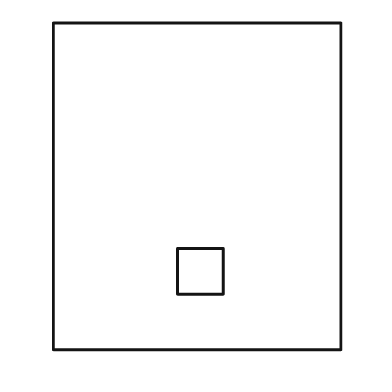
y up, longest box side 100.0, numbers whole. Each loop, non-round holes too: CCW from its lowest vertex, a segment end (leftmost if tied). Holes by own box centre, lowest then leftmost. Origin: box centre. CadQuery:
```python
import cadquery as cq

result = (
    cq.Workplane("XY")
    .moveTo(-44.0, -50.0)
    .lineTo(44.0, -50.0)
    .lineTo(44.0, 50.0)
    .lineTo(-44.0, 50.0)
    .close()
    .moveTo(-6.0, -33.0)
    .lineTo(8.0, -33.0)
    .lineTo(8.0, -19.0)
    .lineTo(-6.0, -19.0)
    .close()
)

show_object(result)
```